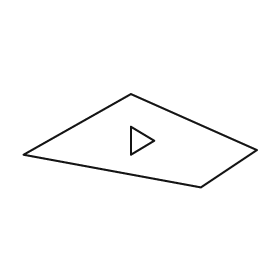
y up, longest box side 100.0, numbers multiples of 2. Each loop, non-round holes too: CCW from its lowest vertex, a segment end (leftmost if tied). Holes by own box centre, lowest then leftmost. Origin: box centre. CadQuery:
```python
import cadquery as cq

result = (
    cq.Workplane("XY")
    .moveTo(26.0, -20.0)
    .lineTo(50.0, -4.0)
    .lineTo(-4.0, 20.0)
    .lineTo(-50.0, -6.0)
    .close()
    .moveTo(-4.0, -6.0)
    .lineTo(6.0, 0.0)
    .lineTo(-4.0, 6.0)
    .close()
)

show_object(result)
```